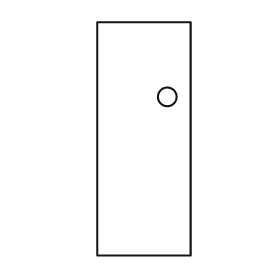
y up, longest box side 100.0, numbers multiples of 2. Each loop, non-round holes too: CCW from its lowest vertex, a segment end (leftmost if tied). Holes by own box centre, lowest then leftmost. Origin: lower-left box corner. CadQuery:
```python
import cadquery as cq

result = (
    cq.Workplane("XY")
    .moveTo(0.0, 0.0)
    .lineTo(40.0, 0.0)
    .lineTo(40.0, 100.0)
    .lineTo(0.0, 100.0)
    .close()
    .moveTo(30.0, 68.0)
    .circle(4.0)
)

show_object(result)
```